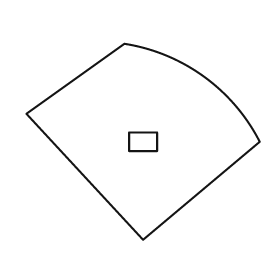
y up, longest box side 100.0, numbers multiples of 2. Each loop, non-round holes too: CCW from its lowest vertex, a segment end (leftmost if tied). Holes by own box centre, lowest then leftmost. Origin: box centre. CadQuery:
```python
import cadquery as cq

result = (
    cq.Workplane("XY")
    .moveTo(0.0, -42.0)
    .lineTo(50.0, 0.0)
    .threePointArc((26.0, 28.0), (-8.0, 42.0))
    .lineTo(-50.0, 12.0)
    .close()
    .moveTo(-6.0, -4.0)
    .lineTo(6.0, -4.0)
    .lineTo(6.0, 4.0)
    .lineTo(-6.0, 4.0)
    .close()
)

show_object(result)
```